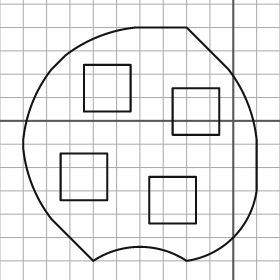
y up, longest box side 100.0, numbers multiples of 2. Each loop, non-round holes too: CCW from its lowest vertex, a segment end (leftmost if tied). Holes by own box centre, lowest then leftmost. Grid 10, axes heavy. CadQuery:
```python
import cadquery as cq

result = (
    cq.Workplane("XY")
    .moveTo(-60.0, -60.0)
    .threePointArc((-40.0, -54.0), (-20.0, -60.0))
    .threePointArc((0.0, -50.0), (10.0, -30.0))
    .lineTo(10.0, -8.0)
    .threePointArc((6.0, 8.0), (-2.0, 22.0))
    .lineTo(-20.0, 40.0)
    .lineTo(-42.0, 40.0)
    .threePointArc((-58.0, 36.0), (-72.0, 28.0))
    .lineTo(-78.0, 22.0)
    .threePointArc((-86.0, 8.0), (-90.0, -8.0))
    .lineTo(-90.0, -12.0)
    .threePointArc((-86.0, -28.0), (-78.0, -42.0))
    .close()
    .moveTo(-36.0, -44.0)
    .lineTo(-16.0, -44.0)
    .lineTo(-16.0, -24.0)
    .lineTo(-36.0, -24.0)
    .close()
    .moveTo(-74.0, -34.0)
    .lineTo(-54.0, -34.0)
    .lineTo(-54.0, -14.0)
    .lineTo(-74.0, -14.0)
    .close()
    .moveTo(-26.0, -6.0)
    .lineTo(-6.0, -6.0)
    .lineTo(-6.0, 14.0)
    .lineTo(-26.0, 14.0)
    .close()
    .moveTo(-64.0, 4.0)
    .lineTo(-44.0, 4.0)
    .lineTo(-44.0, 24.0)
    .lineTo(-64.0, 24.0)
    .close()
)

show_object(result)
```